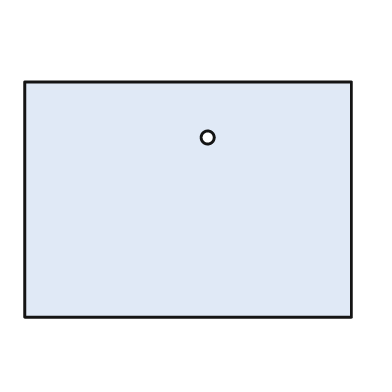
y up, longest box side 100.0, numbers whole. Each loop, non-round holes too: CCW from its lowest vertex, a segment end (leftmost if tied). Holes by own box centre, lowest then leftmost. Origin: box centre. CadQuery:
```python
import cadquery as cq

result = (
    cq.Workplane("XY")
    .moveTo(-50.0, -36.0)
    .lineTo(50.0, -36.0)
    .lineTo(50.0, 36.0)
    .lineTo(-50.0, 36.0)
    .close()
    .moveTo(6.0, 19.0)
    .circle(2.0)
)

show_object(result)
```